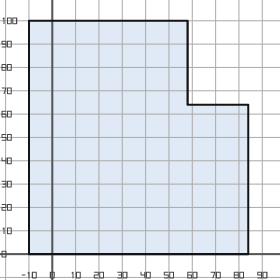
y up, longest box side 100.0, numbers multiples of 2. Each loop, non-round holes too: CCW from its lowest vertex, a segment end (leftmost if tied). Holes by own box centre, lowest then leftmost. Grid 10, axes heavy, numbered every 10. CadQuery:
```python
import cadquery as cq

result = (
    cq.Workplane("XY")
    .moveTo(-10.0, 0.0)
    .lineTo(84.0, 0.0)
    .lineTo(84.0, 64.0)
    .lineTo(58.0, 64.0)
    .lineTo(58.0, 100.0)
    .lineTo(-10.0, 100.0)
    .close()
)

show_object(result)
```